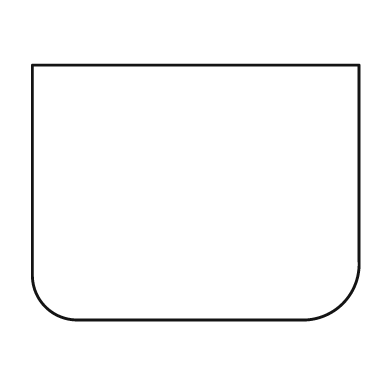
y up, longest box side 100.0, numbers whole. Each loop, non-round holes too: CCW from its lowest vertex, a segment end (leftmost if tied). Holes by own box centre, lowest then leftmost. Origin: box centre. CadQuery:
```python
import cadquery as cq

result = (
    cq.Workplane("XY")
    .moveTo(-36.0, -39.0)
    .lineTo(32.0, -39.0)
    .threePointArc((45.0, -34.0), (50.0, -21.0))
    .lineTo(50.0, 39.0)
    .lineTo(-50.0, 39.0)
    .lineTo(-50.0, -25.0)
    .threePointArc((-46.0, -35.0), (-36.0, -39.0))
    .close()
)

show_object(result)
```